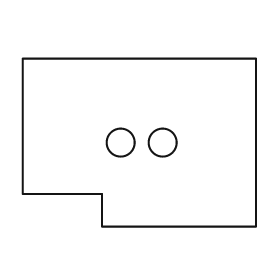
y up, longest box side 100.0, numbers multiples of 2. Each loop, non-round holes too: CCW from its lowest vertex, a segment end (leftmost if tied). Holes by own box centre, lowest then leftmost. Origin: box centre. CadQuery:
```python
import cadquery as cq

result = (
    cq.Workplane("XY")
    .moveTo(-16.0, -36.0)
    .lineTo(50.0, -36.0)
    .lineTo(50.0, 36.0)
    .lineTo(-50.0, 36.0)
    .lineTo(-50.0, -22.0)
    .lineTo(-16.0, -22.0)
    .close()
    .moveTo(-8.0, 0.0)
    .circle(6.0)
    .moveTo(10.0, 0.0)
    .circle(6.0)
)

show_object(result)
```